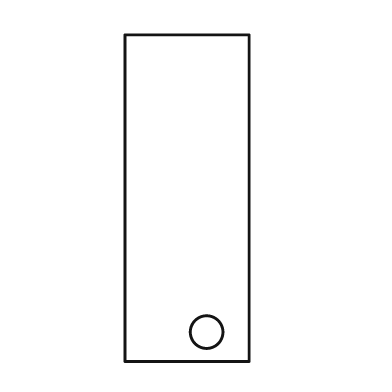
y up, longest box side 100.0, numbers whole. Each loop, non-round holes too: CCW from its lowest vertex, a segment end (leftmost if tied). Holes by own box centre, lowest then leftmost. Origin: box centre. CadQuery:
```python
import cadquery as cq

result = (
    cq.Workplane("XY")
    .moveTo(-19.0, -50.0)
    .lineTo(19.0, -50.0)
    .lineTo(19.0, 50.0)
    .lineTo(-19.0, 50.0)
    .close()
    .moveTo(6.0, -41.0)
    .circle(5.0)
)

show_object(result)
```